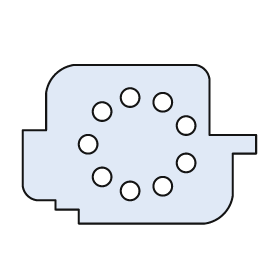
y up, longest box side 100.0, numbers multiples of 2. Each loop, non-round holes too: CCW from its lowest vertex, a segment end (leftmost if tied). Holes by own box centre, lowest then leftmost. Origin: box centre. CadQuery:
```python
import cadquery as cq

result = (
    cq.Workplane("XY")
    .moveTo(-26.0, -34.0)
    .lineTo(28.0, -34.0)
    .threePointArc((36.0, -30.0), (40.0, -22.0))
    .lineTo(40.0, -4.0)
    .lineTo(50.0, -4.0)
    .lineTo(50.0, 4.0)
    .lineTo(30.0, 4.0)
    .lineTo(30.0, 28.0)
    .threePointArc((28.0, 32.0), (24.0, 34.0))
    .lineTo(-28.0, 34.0)
    .threePointArc((-36.0, 30.0), (-40.0, 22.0))
    .lineTo(-40.0, 6.0)
    .lineTo(-50.0, 6.0)
    .lineTo(-50.0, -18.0)
    .threePointArc((-48.0, -22.0), (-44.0, -24.0))
    .lineTo(-36.0, -24.0)
    .lineTo(-36.0, -28.0)
    .lineTo(-26.0, -28.0)
    .close()
    .moveTo(-4.0, -20.0)
    .circle(4.0)
    .moveTo(10.0, -18.0)
    .circle(4.0)
    .moveTo(-16.0, -14.0)
    .circle(4.0)
    .moveTo(20.0, -8.0)
    .circle(4.0)
    .moveTo(-22.0, 0.0)
    .circle(4.0)
    .moveTo(20.0, 8.0)
    .circle(4.0)
    .moveTo(-16.0, 14.0)
    .circle(4.0)
    .moveTo(10.0, 18.0)
    .circle(4.0)
    .moveTo(-4.0, 20.0)
    .circle(4.0)
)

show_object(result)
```